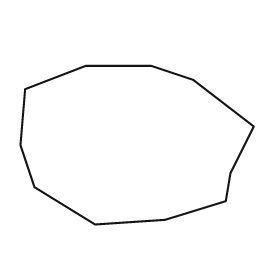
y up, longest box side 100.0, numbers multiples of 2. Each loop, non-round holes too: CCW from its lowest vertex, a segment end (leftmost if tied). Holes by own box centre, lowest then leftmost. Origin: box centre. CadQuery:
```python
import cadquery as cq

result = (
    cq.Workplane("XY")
    .moveTo(-18.0, -34.0)
    .lineTo(12.0, -32.0)
    .lineTo(38.0, -24.0)
    .lineTo(40.0, -12.0)
    .lineTo(50.0, 8.0)
    .lineTo(24.0, 28.0)
    .lineTo(6.0, 34.0)
    .lineTo(-22.0, 34.0)
    .lineTo(-48.0, 24.0)
    .lineTo(-50.0, 0.0)
    .lineTo(-44.0, -18.0)
    .close()
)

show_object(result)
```